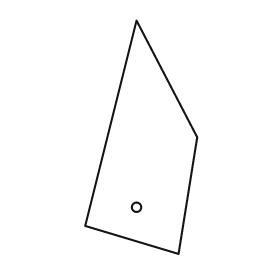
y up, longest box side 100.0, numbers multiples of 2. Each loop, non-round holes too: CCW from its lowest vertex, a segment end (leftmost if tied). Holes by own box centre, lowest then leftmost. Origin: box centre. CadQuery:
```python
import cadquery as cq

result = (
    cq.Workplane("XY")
    .moveTo(16.0, -50.0)
    .lineTo(24.0, 0.0)
    .lineTo(-2.0, 50.0)
    .lineTo(-24.0, -38.0)
    .close()
    .moveTo(-2.0, -30.0)
    .circle(2.0)
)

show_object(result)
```